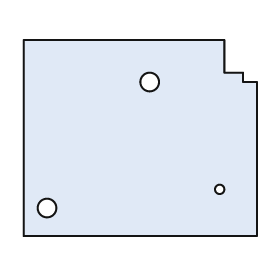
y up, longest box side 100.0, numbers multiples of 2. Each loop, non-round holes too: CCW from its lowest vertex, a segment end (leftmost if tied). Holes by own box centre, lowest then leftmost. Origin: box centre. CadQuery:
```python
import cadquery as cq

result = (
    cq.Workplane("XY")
    .moveTo(-50.0, -42.0)
    .lineTo(50.0, -42.0)
    .lineTo(50.0, 24.0)
    .lineTo(44.0, 24.0)
    .lineTo(44.0, 28.0)
    .lineTo(36.0, 28.0)
    .lineTo(36.0, 42.0)
    .lineTo(-50.0, 42.0)
    .close()
    .moveTo(-40.0, -30.0)
    .circle(4.0)
    .moveTo(34.0, -22.0)
    .circle(2.0)
    .moveTo(4.0, 24.0)
    .circle(4.0)
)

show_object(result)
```